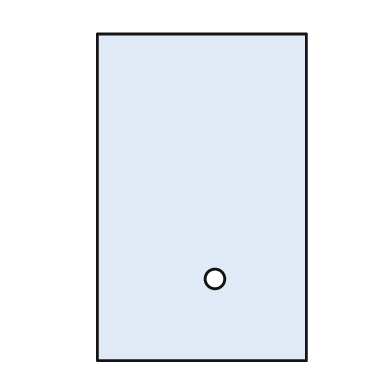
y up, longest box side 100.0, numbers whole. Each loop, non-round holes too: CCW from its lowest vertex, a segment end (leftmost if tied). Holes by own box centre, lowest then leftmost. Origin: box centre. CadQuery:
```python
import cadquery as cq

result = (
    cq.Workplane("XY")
    .moveTo(-32.0, -50.0)
    .lineTo(32.0, -50.0)
    .lineTo(32.0, 50.0)
    .lineTo(-32.0, 50.0)
    .close()
    .moveTo(4.0, -25.0)
    .circle(3.0)
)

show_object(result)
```